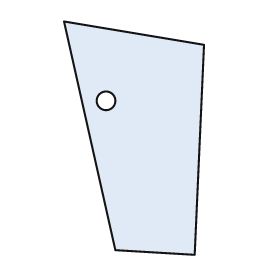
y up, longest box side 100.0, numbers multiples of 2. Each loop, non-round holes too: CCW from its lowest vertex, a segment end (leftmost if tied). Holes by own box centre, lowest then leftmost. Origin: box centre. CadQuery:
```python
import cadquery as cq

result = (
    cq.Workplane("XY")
    .moveTo(26.0, -50.0)
    .lineTo(30.0, 40.0)
    .lineTo(-30.0, 50.0)
    .lineTo(-8.0, -48.0)
    .close()
    .moveTo(-12.0, 16.0)
    .circle(4.0)
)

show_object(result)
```